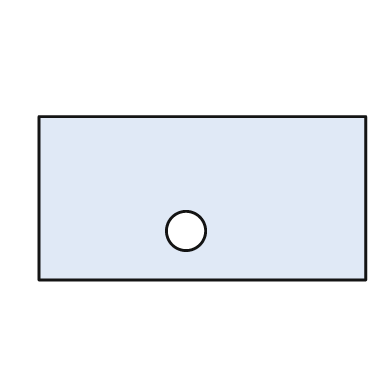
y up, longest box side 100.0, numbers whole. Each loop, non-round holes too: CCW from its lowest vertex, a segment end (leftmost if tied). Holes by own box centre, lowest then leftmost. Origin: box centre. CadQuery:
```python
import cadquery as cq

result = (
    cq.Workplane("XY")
    .moveTo(-50.0, -25.0)
    .lineTo(50.0, -25.0)
    .lineTo(50.0, 25.0)
    .lineTo(-50.0, 25.0)
    .close()
    .moveTo(-5.0, -10.0)
    .circle(6.0)
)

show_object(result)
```